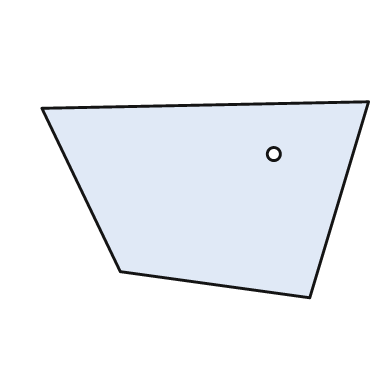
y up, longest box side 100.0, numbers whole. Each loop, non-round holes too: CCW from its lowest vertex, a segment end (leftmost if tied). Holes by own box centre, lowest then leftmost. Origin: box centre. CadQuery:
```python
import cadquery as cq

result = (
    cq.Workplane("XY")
    .moveTo(32.0, -30.0)
    .lineTo(50.0, 30.0)
    .lineTo(-50.0, 28.0)
    .lineTo(-26.0, -22.0)
    .close()
    .moveTo(21.0, 14.0)
    .circle(2.0)
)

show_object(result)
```